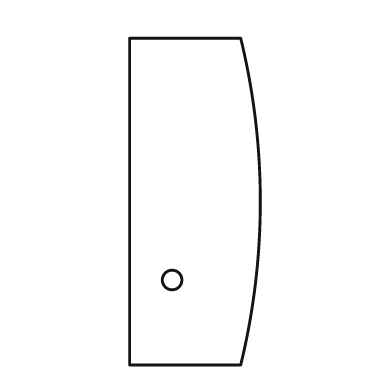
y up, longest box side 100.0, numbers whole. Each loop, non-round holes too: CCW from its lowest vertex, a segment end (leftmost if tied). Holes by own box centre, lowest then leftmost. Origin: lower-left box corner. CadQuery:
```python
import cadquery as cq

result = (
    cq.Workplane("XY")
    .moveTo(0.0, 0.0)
    .lineTo(34.0, 0.0)
    .threePointArc((40.0, 50.0), (34.0, 100.0))
    .lineTo(0.0, 100.0)
    .close()
    .moveTo(13.0, 26.0)
    .circle(3.0)
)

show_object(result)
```